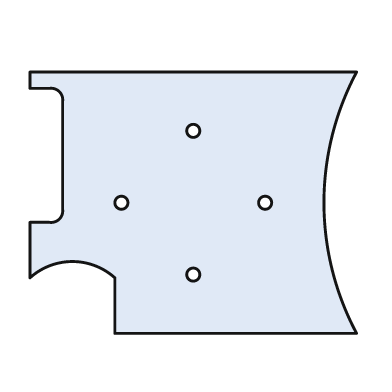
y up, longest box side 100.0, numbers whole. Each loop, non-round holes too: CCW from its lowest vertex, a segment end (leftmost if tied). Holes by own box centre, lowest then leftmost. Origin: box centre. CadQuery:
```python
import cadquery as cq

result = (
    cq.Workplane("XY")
    .moveTo(-24.0, -40.0)
    .lineTo(50.0, -40.0)
    .threePointArc((40.0, 0.0), (50.0, 40.0))
    .lineTo(-50.0, 40.0)
    .lineTo(-50.0, 35.0)
    .lineTo(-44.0, 35.0)
    .threePointArc((-41.0, 34.0), (-40.0, 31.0))
    .lineTo(-40.0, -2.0)
    .threePointArc((-41.0, -5.0), (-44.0, -6.0))
    .lineTo(-50.0, -6.0)
    .lineTo(-50.0, -23.0)
    .threePointArc((-37.0, -18.0), (-24.0, -23.0))
    .close()
    .moveTo(0.0, -22.0)
    .circle(2.0)
    .moveTo(-22.0, 0.0)
    .circle(2.0)
    .moveTo(22.0, 0.0)
    .circle(2.0)
    .moveTo(0.0, 22.0)
    .circle(2.0)
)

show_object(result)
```